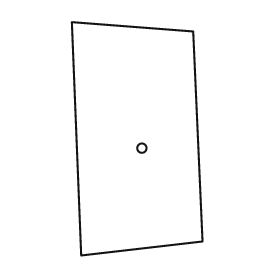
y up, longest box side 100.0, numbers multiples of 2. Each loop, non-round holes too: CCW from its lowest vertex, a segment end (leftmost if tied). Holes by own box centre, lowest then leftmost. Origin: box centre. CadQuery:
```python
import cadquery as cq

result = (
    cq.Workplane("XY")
    .moveTo(-24.0, -50.0)
    .lineTo(28.0, -44.0)
    .lineTo(24.0, 46.0)
    .lineTo(-28.0, 50.0)
    .close()
    .moveTo(2.0, -4.0)
    .circle(2.0)
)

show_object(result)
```